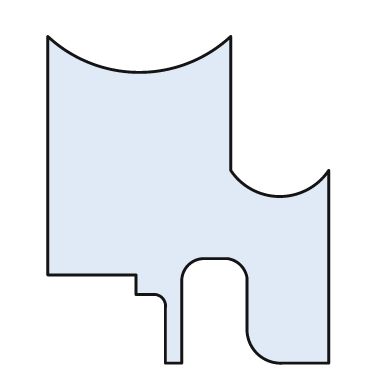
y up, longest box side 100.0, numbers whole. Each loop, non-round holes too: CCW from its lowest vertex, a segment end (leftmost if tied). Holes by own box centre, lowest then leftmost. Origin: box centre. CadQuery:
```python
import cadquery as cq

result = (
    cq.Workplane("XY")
    .moveTo(-7.0, -50.0)
    .lineTo(-2.0, -50.0)
    .lineTo(-2.0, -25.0)
    .threePointArc((0.0, -20.0), (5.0, -18.0))
    .lineTo(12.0, -18.0)
    .threePointArc((16.0, -20.0), (18.0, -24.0))
    .lineTo(18.0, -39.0)
    .threePointArc((21.0, -47.0), (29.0, -50.0))
    .lineTo(43.0, -50.0)
    .lineTo(43.0, 9.0)
    .threePointArc((28.0, 1.0), (13.0, 9.0))
    .lineTo(13.0, 50.0)
    .threePointArc((-15.0, 39.0), (-43.0, 50.0))
    .lineTo(-43.0, -23.0)
    .lineTo(-16.0, -23.0)
    .lineTo(-16.0, -29.0)
    .lineTo(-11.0, -29.0)
    .threePointArc((-8.0, -30.0), (-7.0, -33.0))
    .close()
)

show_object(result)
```